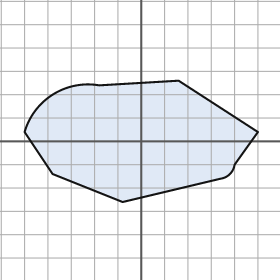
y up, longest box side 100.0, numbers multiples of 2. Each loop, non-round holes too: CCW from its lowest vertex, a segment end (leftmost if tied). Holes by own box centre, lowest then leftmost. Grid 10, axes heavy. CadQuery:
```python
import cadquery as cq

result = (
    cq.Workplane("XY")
    .moveTo(-8.0, -26.0)
    .lineTo(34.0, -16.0)
    .threePointArc((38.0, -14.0), (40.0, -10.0))
    .lineTo(50.0, 4.0)
    .lineTo(16.0, 26.0)
    .lineTo(-18.0, 24.0)
    .threePointArc((-38.0, 20.0), (-50.0, 4.0))
    .lineTo(-38.0, -14.0)
    .close()
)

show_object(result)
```